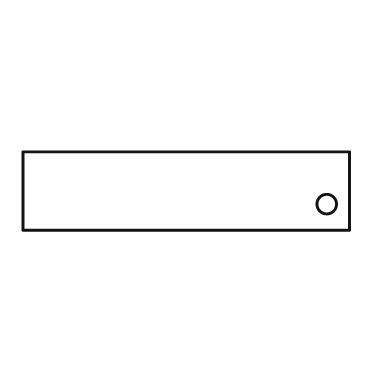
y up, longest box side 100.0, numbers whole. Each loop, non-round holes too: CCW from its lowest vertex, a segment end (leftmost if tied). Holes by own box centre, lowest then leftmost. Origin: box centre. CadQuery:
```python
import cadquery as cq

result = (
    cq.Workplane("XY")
    .moveTo(-50.0, -12.0)
    .lineTo(50.0, -12.0)
    .lineTo(50.0, 12.0)
    .lineTo(-50.0, 12.0)
    .close()
    .moveTo(43.0, -4.0)
    .circle(3.0)
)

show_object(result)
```